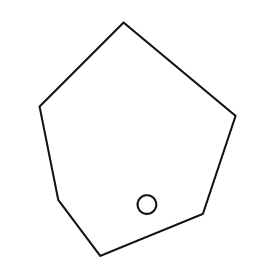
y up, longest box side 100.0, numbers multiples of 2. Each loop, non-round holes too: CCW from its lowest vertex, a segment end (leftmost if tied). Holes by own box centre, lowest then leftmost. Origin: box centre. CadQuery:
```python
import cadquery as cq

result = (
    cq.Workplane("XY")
    .moveTo(-16.0, -50.0)
    .lineTo(28.0, -32.0)
    .lineTo(42.0, 10.0)
    .lineTo(-6.0, 50.0)
    .lineTo(-42.0, 14.0)
    .lineTo(-34.0, -26.0)
    .close()
    .moveTo(4.0, -28.0)
    .circle(4.0)
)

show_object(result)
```